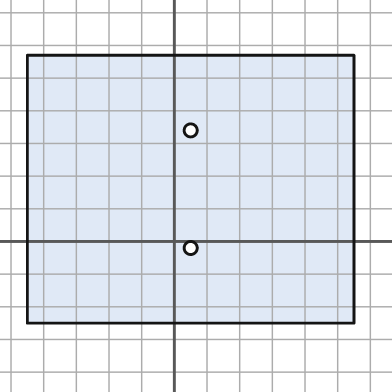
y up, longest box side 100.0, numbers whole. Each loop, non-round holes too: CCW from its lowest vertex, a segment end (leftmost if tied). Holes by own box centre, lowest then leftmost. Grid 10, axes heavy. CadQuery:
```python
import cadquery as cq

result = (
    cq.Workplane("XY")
    .moveTo(-45.0, -25.0)
    .lineTo(55.0, -25.0)
    .lineTo(55.0, 57.0)
    .lineTo(-45.0, 57.0)
    .close()
    .moveTo(5.0, -2.0)
    .circle(2.0)
    .moveTo(5.0, 34.0)
    .circle(2.0)
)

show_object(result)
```